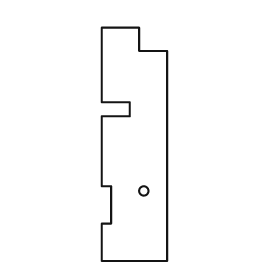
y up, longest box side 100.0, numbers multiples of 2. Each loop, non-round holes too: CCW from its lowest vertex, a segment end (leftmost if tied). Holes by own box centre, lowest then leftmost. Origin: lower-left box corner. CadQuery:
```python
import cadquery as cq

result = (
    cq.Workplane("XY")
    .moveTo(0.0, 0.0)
    .lineTo(28.0, 0.0)
    .lineTo(28.0, 90.0)
    .lineTo(16.0, 90.0)
    .lineTo(16.0, 100.0)
    .lineTo(0.0, 100.0)
    .lineTo(0.0, 68.0)
    .lineTo(12.0, 68.0)
    .lineTo(12.0, 62.0)
    .lineTo(0.0, 62.0)
    .lineTo(0.0, 32.0)
    .lineTo(4.0, 32.0)
    .lineTo(4.0, 16.0)
    .lineTo(0.0, 16.0)
    .close()
    .moveTo(18.0, 30.0)
    .circle(2.0)
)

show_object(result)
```